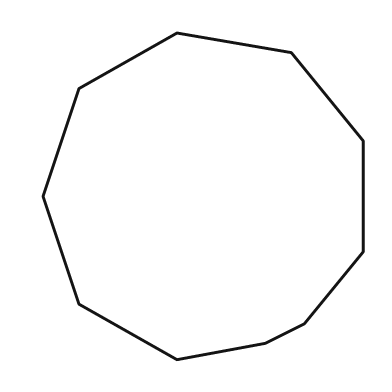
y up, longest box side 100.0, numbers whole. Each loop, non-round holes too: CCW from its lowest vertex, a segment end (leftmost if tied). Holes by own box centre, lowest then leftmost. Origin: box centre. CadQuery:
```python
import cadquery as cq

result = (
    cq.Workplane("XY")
    .moveTo(-8.0, -50.0)
    .lineTo(19.0, -45.0)
    .lineTo(31.0, -39.0)
    .lineTo(49.0, -17.0)
    .lineTo(49.0, 17.0)
    .lineTo(27.0, 44.0)
    .lineTo(-8.0, 50.0)
    .lineTo(-38.0, 33.0)
    .lineTo(-49.0, 0.0)
    .lineTo(-38.0, -33.0)
    .close()
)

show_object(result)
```